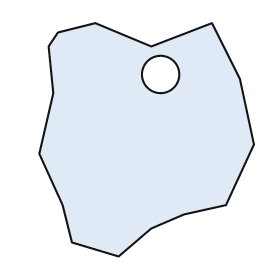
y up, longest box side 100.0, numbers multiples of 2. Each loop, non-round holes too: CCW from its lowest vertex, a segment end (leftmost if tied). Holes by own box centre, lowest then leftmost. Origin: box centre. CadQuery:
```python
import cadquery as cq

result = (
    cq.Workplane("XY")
    .moveTo(-12.0, -50.0)
    .lineTo(2.0, -38.0)
    .lineTo(16.0, -32.0)
    .lineTo(34.0, -28.0)
    .lineTo(46.0, -2.0)
    .lineTo(40.0, 26.0)
    .lineTo(28.0, 50.0)
    .lineTo(2.0, 40.0)
    .lineTo(-22.0, 50.0)
    .lineTo(-38.0, 46.0)
    .lineTo(-42.0, 40.0)
    .lineTo(-40.0, 20.0)
    .lineTo(-46.0, -6.0)
    .lineTo(-36.0, -28.0)
    .lineTo(-32.0, -44.0)
    .close()
    .moveTo(6.0, 28.0)
    .circle(8.0)
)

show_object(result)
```